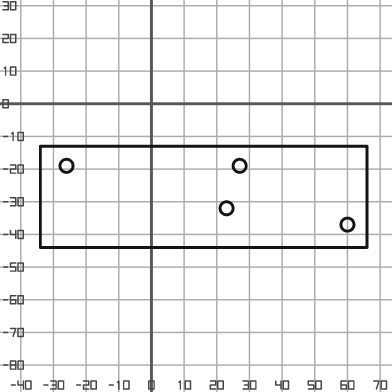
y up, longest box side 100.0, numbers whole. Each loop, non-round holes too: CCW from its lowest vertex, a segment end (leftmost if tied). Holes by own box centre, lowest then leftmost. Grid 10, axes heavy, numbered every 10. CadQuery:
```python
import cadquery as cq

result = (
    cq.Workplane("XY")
    .moveTo(-34.0, -44.0)
    .lineTo(66.0, -44.0)
    .lineTo(66.0, -13.0)
    .lineTo(-34.0, -13.0)
    .close()
    .moveTo(60.0, -37.0)
    .circle(2.0)
    .moveTo(23.0, -32.0)
    .circle(2.0)
    .moveTo(-26.0, -19.0)
    .circle(2.0)
    .moveTo(27.0, -19.0)
    .circle(2.0)
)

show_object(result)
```